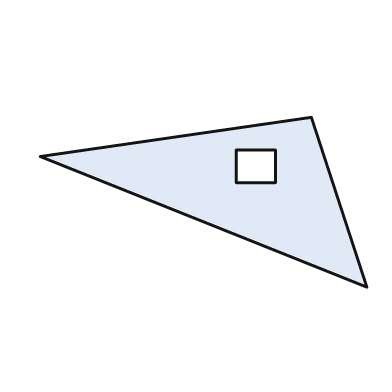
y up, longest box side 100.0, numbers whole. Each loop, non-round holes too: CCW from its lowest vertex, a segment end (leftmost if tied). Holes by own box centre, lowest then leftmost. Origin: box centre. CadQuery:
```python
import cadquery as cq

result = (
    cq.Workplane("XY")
    .moveTo(50.0, -26.0)
    .lineTo(33.0, 26.0)
    .lineTo(-50.0, 14.0)
    .close()
    .moveTo(10.0, 6.0)
    .lineTo(22.0, 6.0)
    .lineTo(22.0, 16.0)
    .lineTo(10.0, 16.0)
    .close()
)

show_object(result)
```